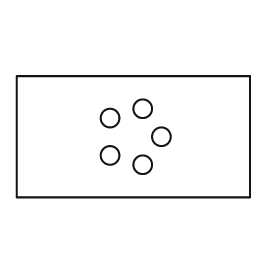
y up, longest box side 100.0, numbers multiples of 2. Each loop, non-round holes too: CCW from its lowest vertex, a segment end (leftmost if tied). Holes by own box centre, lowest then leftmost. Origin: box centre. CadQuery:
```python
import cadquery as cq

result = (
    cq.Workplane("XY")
    .moveTo(-50.0, -26.0)
    .lineTo(50.0, -26.0)
    .lineTo(50.0, 26.0)
    .lineTo(-50.0, 26.0)
    .close()
    .moveTo(4.0, -12.0)
    .circle(4.0)
    .moveTo(-10.0, -8.0)
    .circle(4.0)
    .moveTo(12.0, 0.0)
    .circle(4.0)
    .moveTo(-10.0, 8.0)
    .circle(4.0)
    .moveTo(4.0, 12.0)
    .circle(4.0)
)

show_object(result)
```